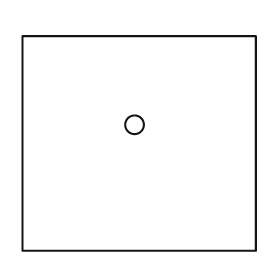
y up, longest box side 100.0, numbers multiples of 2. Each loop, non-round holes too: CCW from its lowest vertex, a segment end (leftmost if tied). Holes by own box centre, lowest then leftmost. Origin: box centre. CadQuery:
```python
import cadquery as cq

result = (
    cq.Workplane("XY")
    .moveTo(-50.0, -46.0)
    .lineTo(50.0, -46.0)
    .lineTo(50.0, 46.0)
    .lineTo(-50.0, 46.0)
    .close()
    .moveTo(-2.0, 8.0)
    .circle(4.0)
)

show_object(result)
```